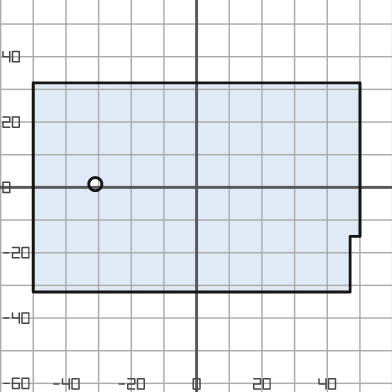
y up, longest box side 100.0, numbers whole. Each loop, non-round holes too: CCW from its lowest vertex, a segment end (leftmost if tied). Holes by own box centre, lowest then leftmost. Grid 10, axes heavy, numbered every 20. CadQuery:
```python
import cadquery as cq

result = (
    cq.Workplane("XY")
    .moveTo(-50.0, -32.0)
    .lineTo(47.0, -32.0)
    .lineTo(47.0, -15.0)
    .lineTo(50.0, -15.0)
    .lineTo(50.0, 32.0)
    .lineTo(-50.0, 32.0)
    .close()
    .moveTo(-31.0, 1.0)
    .circle(2.0)
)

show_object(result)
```